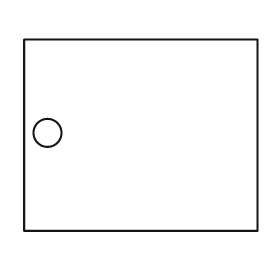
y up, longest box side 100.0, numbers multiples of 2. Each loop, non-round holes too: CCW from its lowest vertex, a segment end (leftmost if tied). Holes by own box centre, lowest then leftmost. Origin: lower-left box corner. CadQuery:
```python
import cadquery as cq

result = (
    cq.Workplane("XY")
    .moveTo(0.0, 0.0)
    .lineTo(100.0, 0.0)
    .lineTo(100.0, 82.0)
    .lineTo(0.0, 82.0)
    .close()
    .moveTo(10.0, 42.0)
    .circle(6.0)
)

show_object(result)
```